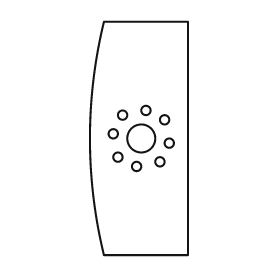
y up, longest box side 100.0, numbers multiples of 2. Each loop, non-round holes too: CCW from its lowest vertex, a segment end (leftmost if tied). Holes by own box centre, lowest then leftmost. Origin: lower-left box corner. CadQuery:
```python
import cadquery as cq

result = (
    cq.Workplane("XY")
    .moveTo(6.0, 0.0)
    .lineTo(42.0, 0.0)
    .lineTo(42.0, 100.0)
    .lineTo(6.0, 100.0)
    .threePointArc((0.0, 50.0), (6.0, 0.0))
    .close()
    .moveTo(20.0, 38.0)
    .circle(2.0)
    .moveTo(30.0, 40.0)
    .circle(2.0)
    .moveTo(12.0, 42.0)
    .circle(2.0)
    .moveTo(34.0, 48.0)
    .circle(2.0)
    .moveTo(22.0, 50.0)
    .circle(6.0)
    .moveTo(10.0, 52.0)
    .circle(2.0)
    .moveTo(32.0, 58.0)
    .circle(2.0)
    .moveTo(14.0, 60.0)
    .circle(2.0)
    .moveTo(24.0, 62.0)
    .circle(2.0)
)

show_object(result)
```